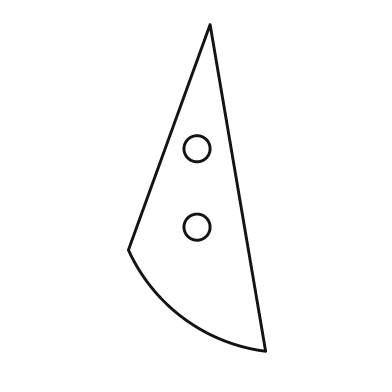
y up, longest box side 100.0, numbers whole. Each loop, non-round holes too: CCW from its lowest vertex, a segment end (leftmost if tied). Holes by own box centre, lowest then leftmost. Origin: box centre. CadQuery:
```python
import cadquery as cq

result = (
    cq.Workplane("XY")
    .moveTo(21.0, -50.0)
    .lineTo(4.0, 50.0)
    .lineTo(-21.0, -19.0)
    .threePointArc((-4.0, -40.0), (21.0, -50.0))
    .close()
    .moveTo(0.0, -12.0)
    .circle(4.0)
    .moveTo(0.0, 12.0)
    .circle(4.0)
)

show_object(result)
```